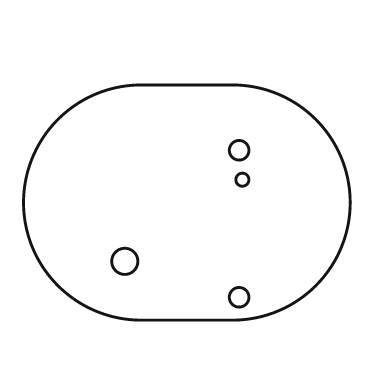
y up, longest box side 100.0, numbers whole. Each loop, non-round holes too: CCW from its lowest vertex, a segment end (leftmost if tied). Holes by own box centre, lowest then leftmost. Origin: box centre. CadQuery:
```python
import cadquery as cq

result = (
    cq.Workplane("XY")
    .moveTo(-14.0, -36.0)
    .lineTo(14.0, -36.0)
    .threePointArc((50.0, 0.0), (14.0, 36.0))
    .lineTo(-14.0, 36.0)
    .threePointArc((-50.0, 0.0), (-14.0, -36.0))
    .close()
    .moveTo(16.0, -29.0)
    .circle(3.0)
    .moveTo(-19.0, -18.0)
    .circle(4.0)
    .moveTo(17.0, 7.0)
    .circle(2.0)
    .moveTo(16.0, 16.0)
    .circle(3.0)
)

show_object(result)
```